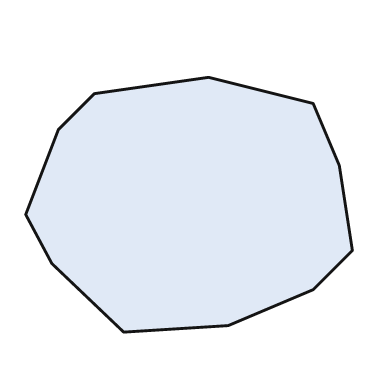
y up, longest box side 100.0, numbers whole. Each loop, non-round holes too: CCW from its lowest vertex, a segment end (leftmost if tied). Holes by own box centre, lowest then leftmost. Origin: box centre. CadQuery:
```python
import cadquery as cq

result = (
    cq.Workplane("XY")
    .moveTo(-20.0, -39.0)
    .lineTo(12.0, -37.0)
    .lineTo(38.0, -26.0)
    .lineTo(50.0, -14.0)
    .lineTo(46.0, 12.0)
    .lineTo(38.0, 31.0)
    .lineTo(6.0, 39.0)
    .lineTo(-29.0, 34.0)
    .lineTo(-40.0, 23.0)
    .lineTo(-50.0, -3.0)
    .lineTo(-42.0, -18.0)
    .close()
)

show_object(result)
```